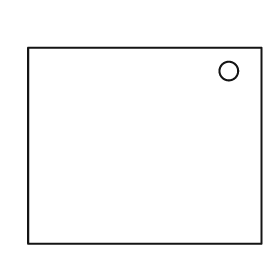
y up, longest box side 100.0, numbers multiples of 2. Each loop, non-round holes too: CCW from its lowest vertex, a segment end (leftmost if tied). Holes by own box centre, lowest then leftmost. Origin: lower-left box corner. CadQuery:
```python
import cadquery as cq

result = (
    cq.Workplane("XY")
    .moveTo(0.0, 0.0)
    .lineTo(100.0, 0.0)
    .lineTo(100.0, 84.0)
    .lineTo(0.0, 84.0)
    .close()
    .moveTo(86.0, 74.0)
    .circle(4.0)
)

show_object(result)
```